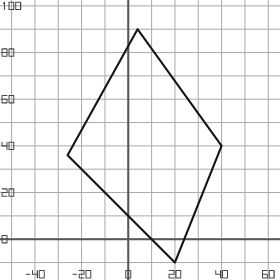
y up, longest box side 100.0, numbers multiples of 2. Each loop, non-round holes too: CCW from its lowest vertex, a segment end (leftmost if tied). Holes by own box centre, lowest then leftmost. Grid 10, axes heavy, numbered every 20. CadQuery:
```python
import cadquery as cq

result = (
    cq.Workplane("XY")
    .moveTo(20.0, -10.0)
    .lineTo(40.0, 40.0)
    .lineTo(4.0, 90.0)
    .lineTo(-26.0, 36.0)
    .close()
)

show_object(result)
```